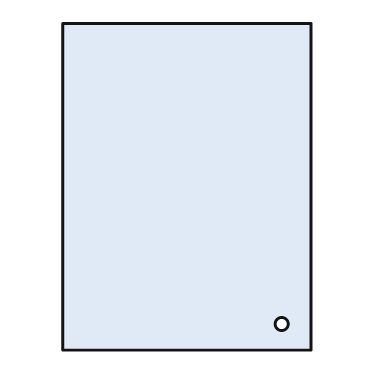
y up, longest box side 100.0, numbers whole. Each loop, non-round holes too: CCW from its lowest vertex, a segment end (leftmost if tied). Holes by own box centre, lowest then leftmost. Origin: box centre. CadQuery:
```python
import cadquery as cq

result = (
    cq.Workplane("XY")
    .moveTo(-38.0, -50.0)
    .lineTo(38.0, -50.0)
    .lineTo(38.0, 50.0)
    .lineTo(-38.0, 50.0)
    .close()
    .moveTo(29.0, -42.0)
    .circle(2.0)
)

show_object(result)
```